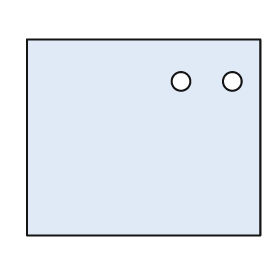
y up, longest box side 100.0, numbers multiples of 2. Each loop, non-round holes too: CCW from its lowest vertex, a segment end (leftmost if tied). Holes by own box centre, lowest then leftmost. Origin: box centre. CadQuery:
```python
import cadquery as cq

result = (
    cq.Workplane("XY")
    .moveTo(-50.0, -42.0)
    .lineTo(50.0, -42.0)
    .lineTo(50.0, 42.0)
    .lineTo(-50.0, 42.0)
    .close()
    .moveTo(16.0, 24.0)
    .circle(4.0)
    .moveTo(38.0, 24.0)
    .circle(4.0)
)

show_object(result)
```